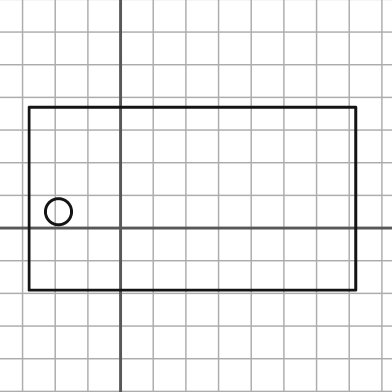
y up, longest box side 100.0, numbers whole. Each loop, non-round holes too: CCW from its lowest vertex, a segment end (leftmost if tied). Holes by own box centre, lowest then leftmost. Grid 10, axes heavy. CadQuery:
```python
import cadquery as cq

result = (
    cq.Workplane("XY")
    .moveTo(-28.0, -19.0)
    .lineTo(72.0, -19.0)
    .lineTo(72.0, 37.0)
    .lineTo(-28.0, 37.0)
    .close()
    .moveTo(-19.0, 5.0)
    .circle(4.0)
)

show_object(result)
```